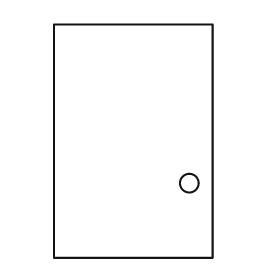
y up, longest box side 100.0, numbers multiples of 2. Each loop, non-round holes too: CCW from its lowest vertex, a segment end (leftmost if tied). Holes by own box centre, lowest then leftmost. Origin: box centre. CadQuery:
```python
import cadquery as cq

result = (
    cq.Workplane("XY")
    .moveTo(-34.0, -50.0)
    .lineTo(34.0, -50.0)
    .lineTo(34.0, 50.0)
    .lineTo(-34.0, 50.0)
    .close()
    .moveTo(24.0, -18.0)
    .circle(4.0)
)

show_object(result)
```